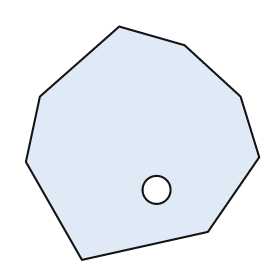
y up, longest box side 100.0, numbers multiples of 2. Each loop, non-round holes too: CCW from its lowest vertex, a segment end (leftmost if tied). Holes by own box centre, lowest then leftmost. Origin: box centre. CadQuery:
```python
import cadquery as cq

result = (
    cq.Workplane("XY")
    .moveTo(-26.0, -50.0)
    .lineTo(28.0, -38.0)
    .lineTo(50.0, -6.0)
    .lineTo(42.0, 20.0)
    .lineTo(18.0, 42.0)
    .lineTo(-10.0, 50.0)
    .lineTo(-44.0, 20.0)
    .lineTo(-50.0, -8.0)
    .close()
    .moveTo(6.0, -20.0)
    .circle(6.0)
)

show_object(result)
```